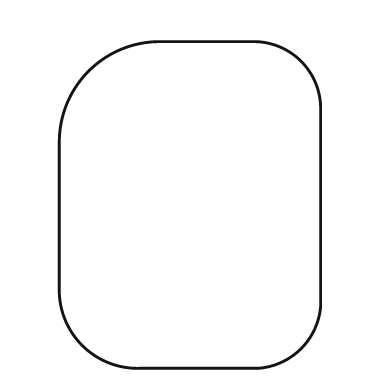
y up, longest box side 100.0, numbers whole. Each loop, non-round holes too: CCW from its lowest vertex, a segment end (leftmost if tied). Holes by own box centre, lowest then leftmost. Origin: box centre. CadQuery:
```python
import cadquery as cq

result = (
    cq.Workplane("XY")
    .moveTo(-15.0, -50.0)
    .lineTo(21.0, -50.0)
    .threePointArc((34.0, -44.0), (40.0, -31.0))
    .lineTo(40.0, 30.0)
    .threePointArc((34.0, 44.0), (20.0, 50.0))
    .lineTo(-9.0, 50.0)
    .threePointArc((-31.0, 41.0), (-40.0, 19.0))
    .lineTo(-40.0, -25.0)
    .threePointArc((-33.0, -43.0), (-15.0, -50.0))
    .close()
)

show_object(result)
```